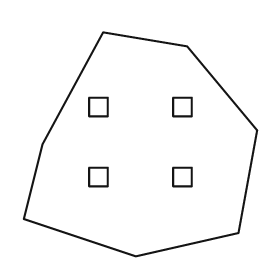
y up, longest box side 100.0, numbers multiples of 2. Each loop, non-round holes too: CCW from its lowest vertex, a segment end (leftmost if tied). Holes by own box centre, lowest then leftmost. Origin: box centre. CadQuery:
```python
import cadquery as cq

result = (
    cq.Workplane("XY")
    .moveTo(-2.0, -48.0)
    .lineTo(42.0, -38.0)
    .lineTo(50.0, 6.0)
    .lineTo(20.0, 42.0)
    .lineTo(-16.0, 48.0)
    .lineTo(-42.0, 0.0)
    .lineTo(-50.0, -32.0)
    .close()
    .moveTo(-22.0, -18.0)
    .lineTo(-14.0, -18.0)
    .lineTo(-14.0, -10.0)
    .lineTo(-22.0, -10.0)
    .close()
    .moveTo(14.0, -18.0)
    .lineTo(22.0, -18.0)
    .lineTo(22.0, -10.0)
    .lineTo(14.0, -10.0)
    .close()
    .moveTo(-22.0, 12.0)
    .lineTo(-14.0, 12.0)
    .lineTo(-14.0, 20.0)
    .lineTo(-22.0, 20.0)
    .close()
    .moveTo(14.0, 12.0)
    .lineTo(22.0, 12.0)
    .lineTo(22.0, 20.0)
    .lineTo(14.0, 20.0)
    .close()
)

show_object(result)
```